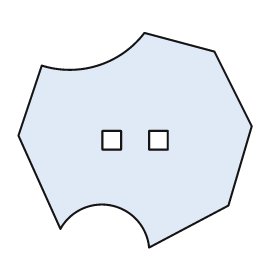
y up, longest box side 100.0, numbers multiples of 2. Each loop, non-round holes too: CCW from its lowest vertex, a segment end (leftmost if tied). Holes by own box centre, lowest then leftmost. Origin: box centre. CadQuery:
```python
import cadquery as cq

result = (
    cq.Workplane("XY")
    .moveTo(6.0, -46.0)
    .lineTo(40.0, -28.0)
    .lineTo(50.0, 6.0)
    .lineTo(34.0, 38.0)
    .lineTo(4.0, 46.0)
    .threePointArc((-16.0, 32.0), (-40.0, 32.0))
    .lineTo(-50.0, 2.0)
    .lineTo(-32.0, -38.0)
    .threePointArc((-10.0, -28.0), (6.0, -46.0))
    .close()
    .moveTo(-14.0, -4.0)
    .lineTo(-6.0, -4.0)
    .lineTo(-6.0, 4.0)
    .lineTo(-14.0, 4.0)
    .close()
    .moveTo(6.0, -4.0)
    .lineTo(14.0, -4.0)
    .lineTo(14.0, 4.0)
    .lineTo(6.0, 4.0)
    .close()
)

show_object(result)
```